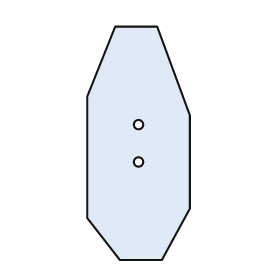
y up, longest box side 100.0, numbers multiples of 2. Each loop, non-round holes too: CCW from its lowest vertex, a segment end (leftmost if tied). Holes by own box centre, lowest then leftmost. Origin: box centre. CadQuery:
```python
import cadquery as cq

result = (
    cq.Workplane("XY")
    .moveTo(-8.0, -50.0)
    .lineTo(10.0, -50.0)
    .lineTo(22.0, -28.0)
    .lineTo(22.0, 12.0)
    .lineTo(8.0, 50.0)
    .lineTo(-10.0, 50.0)
    .lineTo(-22.0, 20.0)
    .lineTo(-22.0, -32.0)
    .close()
    .moveTo(0.0, -8.0)
    .circle(2.0)
    .moveTo(0.0, 8.0)
    .circle(2.0)
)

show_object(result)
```